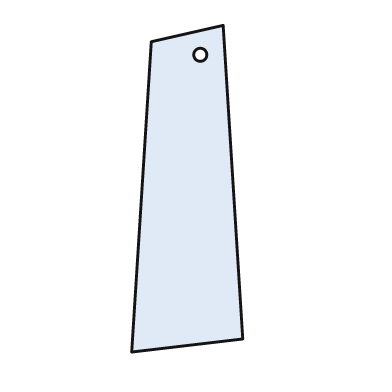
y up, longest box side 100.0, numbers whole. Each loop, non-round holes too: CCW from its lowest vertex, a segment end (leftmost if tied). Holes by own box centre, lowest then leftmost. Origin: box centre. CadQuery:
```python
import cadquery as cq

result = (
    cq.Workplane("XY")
    .moveTo(-17.0, -50.0)
    .lineTo(17.0, -46.0)
    .lineTo(11.0, 50.0)
    .lineTo(-11.0, 45.0)
    .close()
    .moveTo(4.0, 41.0)
    .circle(2.0)
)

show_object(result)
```